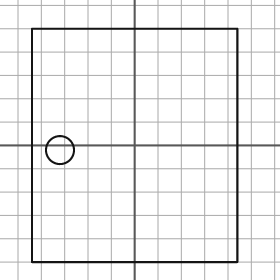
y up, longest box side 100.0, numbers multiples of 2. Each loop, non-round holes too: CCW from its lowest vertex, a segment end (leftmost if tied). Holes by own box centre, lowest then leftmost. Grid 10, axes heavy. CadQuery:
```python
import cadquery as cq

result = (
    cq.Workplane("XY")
    .moveTo(-44.0, -50.0)
    .lineTo(44.0, -50.0)
    .lineTo(44.0, 50.0)
    .lineTo(-44.0, 50.0)
    .close()
    .moveTo(-32.0, -2.0)
    .circle(6.0)
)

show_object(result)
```